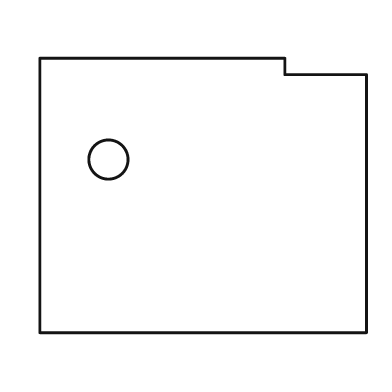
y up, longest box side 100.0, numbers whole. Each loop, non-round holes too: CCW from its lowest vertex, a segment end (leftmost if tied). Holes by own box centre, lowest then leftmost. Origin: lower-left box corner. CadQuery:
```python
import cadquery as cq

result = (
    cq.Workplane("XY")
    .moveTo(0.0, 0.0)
    .lineTo(100.0, 0.0)
    .lineTo(100.0, 79.0)
    .lineTo(75.0, 79.0)
    .lineTo(75.0, 84.0)
    .lineTo(0.0, 84.0)
    .close()
    .moveTo(21.0, 53.0)
    .circle(6.0)
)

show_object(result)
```